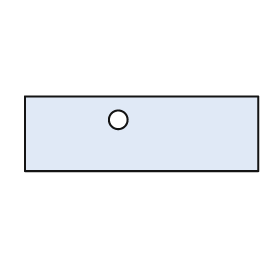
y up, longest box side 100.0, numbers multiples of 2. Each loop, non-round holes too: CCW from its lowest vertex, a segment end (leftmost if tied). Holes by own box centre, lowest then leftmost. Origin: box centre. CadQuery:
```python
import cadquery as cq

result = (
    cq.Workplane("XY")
    .moveTo(-50.0, -16.0)
    .lineTo(50.0, -16.0)
    .lineTo(50.0, 16.0)
    .lineTo(-50.0, 16.0)
    .close()
    .moveTo(-10.0, 6.0)
    .circle(4.0)
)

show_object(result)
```